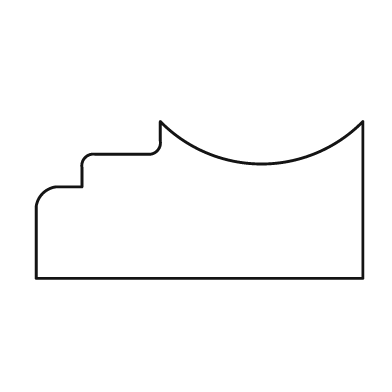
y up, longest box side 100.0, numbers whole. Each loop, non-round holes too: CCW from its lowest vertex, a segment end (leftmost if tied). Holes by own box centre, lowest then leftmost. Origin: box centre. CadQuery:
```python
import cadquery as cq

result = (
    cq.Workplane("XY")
    .moveTo(-50.0, -24.0)
    .lineTo(50.0, -24.0)
    .lineTo(50.0, 24.0)
    .threePointArc((19.0, 11.0), (-12.0, 24.0))
    .lineTo(-12.0, 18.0)
    .threePointArc((-13.0, 15.0), (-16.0, 14.0))
    .lineTo(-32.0, 14.0)
    .threePointArc((-35.0, 13.0), (-36.0, 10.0))
    .lineTo(-36.0, 4.0)
    .lineTo(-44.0, 4.0)
    .threePointArc((-48.0, 2.0), (-50.0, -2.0))
    .close()
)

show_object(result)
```